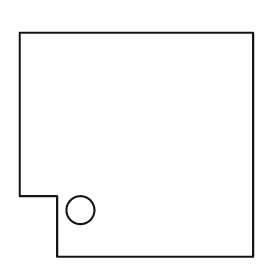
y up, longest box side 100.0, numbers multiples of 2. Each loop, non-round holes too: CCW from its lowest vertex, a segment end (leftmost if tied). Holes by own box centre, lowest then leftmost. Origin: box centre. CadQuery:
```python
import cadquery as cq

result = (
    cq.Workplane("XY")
    .moveTo(-34.0, -48.0)
    .lineTo(50.0, -48.0)
    .lineTo(50.0, 48.0)
    .lineTo(-50.0, 48.0)
    .lineTo(-50.0, -22.0)
    .lineTo(-34.0, -22.0)
    .close()
    .moveTo(-24.0, -28.0)
    .circle(6.0)
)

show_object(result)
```